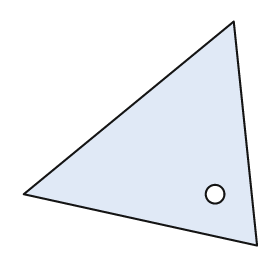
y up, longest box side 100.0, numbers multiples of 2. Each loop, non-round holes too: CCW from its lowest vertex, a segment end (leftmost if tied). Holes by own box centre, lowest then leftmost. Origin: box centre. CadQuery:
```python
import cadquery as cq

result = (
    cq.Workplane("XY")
    .moveTo(50.0, -48.0)
    .lineTo(40.0, 48.0)
    .lineTo(-50.0, -26.0)
    .close()
    .moveTo(32.0, -26.0)
    .circle(4.0)
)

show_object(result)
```